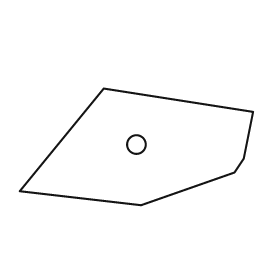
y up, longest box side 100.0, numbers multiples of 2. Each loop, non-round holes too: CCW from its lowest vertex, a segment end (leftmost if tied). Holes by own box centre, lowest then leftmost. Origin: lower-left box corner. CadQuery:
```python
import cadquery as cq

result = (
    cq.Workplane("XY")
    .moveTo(52.0, 0.0)
    .lineTo(92.0, 14.0)
    .lineTo(96.0, 20.0)
    .lineTo(100.0, 40.0)
    .lineTo(36.0, 50.0)
    .lineTo(0.0, 6.0)
    .close()
    .moveTo(50.0, 26.0)
    .circle(4.0)
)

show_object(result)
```